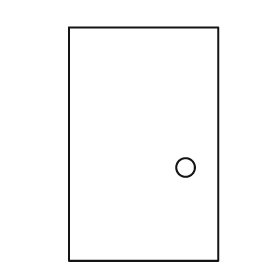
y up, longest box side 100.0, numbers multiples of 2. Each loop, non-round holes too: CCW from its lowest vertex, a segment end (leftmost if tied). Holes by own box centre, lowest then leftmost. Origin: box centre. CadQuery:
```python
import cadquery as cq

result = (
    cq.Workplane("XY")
    .moveTo(-32.0, -50.0)
    .lineTo(32.0, -50.0)
    .lineTo(32.0, 50.0)
    .lineTo(-32.0, 50.0)
    .close()
    .moveTo(18.0, -10.0)
    .circle(4.0)
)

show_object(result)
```